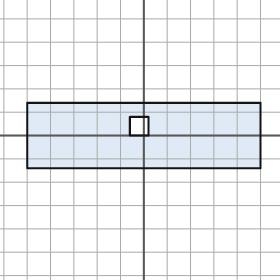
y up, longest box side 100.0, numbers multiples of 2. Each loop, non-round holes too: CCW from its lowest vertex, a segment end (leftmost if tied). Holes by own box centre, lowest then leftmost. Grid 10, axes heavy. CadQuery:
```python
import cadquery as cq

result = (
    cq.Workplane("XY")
    .moveTo(-50.0, -14.0)
    .lineTo(50.0, -14.0)
    .lineTo(50.0, 14.0)
    .lineTo(-50.0, 14.0)
    .close()
    .moveTo(-6.0, 0.0)
    .lineTo(2.0, 0.0)
    .lineTo(2.0, 8.0)
    .lineTo(-6.0, 8.0)
    .close()
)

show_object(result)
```